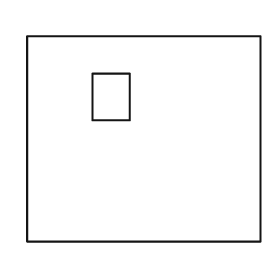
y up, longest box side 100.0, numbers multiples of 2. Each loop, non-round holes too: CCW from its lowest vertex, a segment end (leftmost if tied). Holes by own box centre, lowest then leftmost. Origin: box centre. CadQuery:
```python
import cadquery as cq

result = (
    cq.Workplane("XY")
    .moveTo(-50.0, -44.0)
    .lineTo(50.0, -44.0)
    .lineTo(50.0, 44.0)
    .lineTo(-50.0, 44.0)
    .close()
    .moveTo(-22.0, 8.0)
    .lineTo(-6.0, 8.0)
    .lineTo(-6.0, 28.0)
    .lineTo(-22.0, 28.0)
    .close()
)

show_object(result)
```